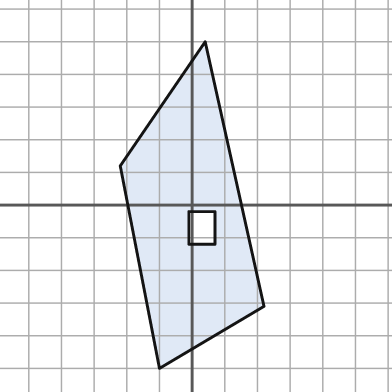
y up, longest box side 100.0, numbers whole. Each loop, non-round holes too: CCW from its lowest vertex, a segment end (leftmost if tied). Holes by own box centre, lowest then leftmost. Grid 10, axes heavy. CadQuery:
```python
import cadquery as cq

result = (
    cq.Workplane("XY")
    .moveTo(-10.0, -50.0)
    .lineTo(22.0, -31.0)
    .lineTo(4.0, 50.0)
    .lineTo(-22.0, 12.0)
    .close()
    .moveTo(-1.0, -12.0)
    .lineTo(7.0, -12.0)
    .lineTo(7.0, -2.0)
    .lineTo(-1.0, -2.0)
    .close()
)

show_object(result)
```